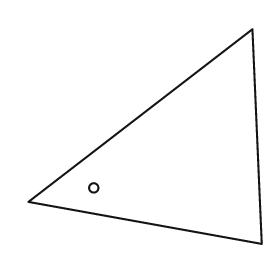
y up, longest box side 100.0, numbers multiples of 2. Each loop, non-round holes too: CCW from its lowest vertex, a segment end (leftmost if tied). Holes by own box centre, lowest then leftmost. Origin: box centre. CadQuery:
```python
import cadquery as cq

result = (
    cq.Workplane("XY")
    .moveTo(50.0, -46.0)
    .lineTo(46.0, 46.0)
    .lineTo(-50.0, -28.0)
    .close()
    .moveTo(-22.0, -22.0)
    .circle(2.0)
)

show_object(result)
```